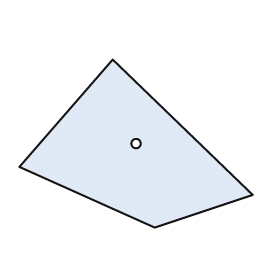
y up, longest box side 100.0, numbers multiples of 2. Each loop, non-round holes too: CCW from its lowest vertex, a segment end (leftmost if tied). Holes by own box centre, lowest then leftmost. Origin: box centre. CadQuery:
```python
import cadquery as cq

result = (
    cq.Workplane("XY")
    .moveTo(8.0, -36.0)
    .lineTo(50.0, -22.0)
    .lineTo(-10.0, 36.0)
    .lineTo(-50.0, -10.0)
    .close()
    .moveTo(0.0, 0.0)
    .circle(2.0)
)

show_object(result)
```